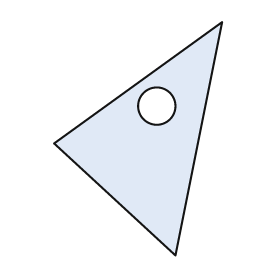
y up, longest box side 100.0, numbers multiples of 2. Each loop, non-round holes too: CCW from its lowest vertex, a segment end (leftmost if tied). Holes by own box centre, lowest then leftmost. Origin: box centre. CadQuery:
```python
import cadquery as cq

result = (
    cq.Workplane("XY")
    .moveTo(16.0, -50.0)
    .lineTo(36.0, 50.0)
    .lineTo(-36.0, -2.0)
    .close()
    .moveTo(8.0, 14.0)
    .circle(8.0)
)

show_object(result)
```